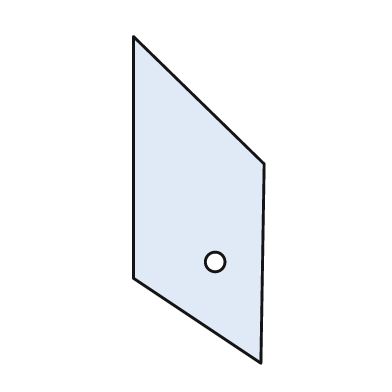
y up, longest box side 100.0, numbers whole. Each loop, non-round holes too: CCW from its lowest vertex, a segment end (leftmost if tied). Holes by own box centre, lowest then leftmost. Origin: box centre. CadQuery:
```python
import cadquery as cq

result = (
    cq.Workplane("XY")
    .moveTo(19.0, -50.0)
    .lineTo(20.0, 11.0)
    .lineTo(-20.0, 50.0)
    .lineTo(-20.0, -24.0)
    .close()
    .moveTo(5.0, -19.0)
    .circle(3.0)
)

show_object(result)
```